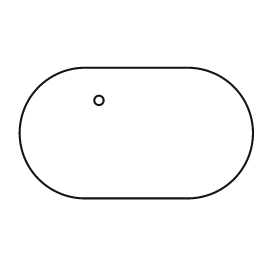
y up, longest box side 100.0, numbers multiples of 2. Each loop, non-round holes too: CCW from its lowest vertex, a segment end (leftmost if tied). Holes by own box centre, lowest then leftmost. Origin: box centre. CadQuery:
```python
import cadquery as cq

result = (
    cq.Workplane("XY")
    .moveTo(-22.0, -28.0)
    .lineTo(22.0, -28.0)
    .threePointArc((50.0, 0.0), (22.0, 28.0))
    .lineTo(-22.0, 28.0)
    .threePointArc((-50.0, 0.0), (-22.0, -28.0))
    .close()
    .moveTo(-16.0, 14.0)
    .circle(2.0)
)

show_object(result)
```